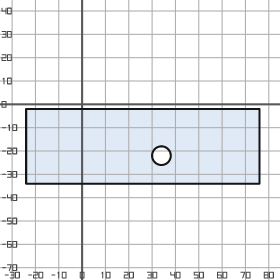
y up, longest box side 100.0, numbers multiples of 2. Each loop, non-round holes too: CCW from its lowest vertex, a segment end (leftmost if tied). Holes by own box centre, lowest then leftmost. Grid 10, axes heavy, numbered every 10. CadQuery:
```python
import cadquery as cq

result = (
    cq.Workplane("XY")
    .moveTo(-24.0, -34.0)
    .lineTo(76.0, -34.0)
    .lineTo(76.0, -2.0)
    .lineTo(-24.0, -2.0)
    .close()
    .moveTo(34.0, -22.0)
    .circle(4.0)
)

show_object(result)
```